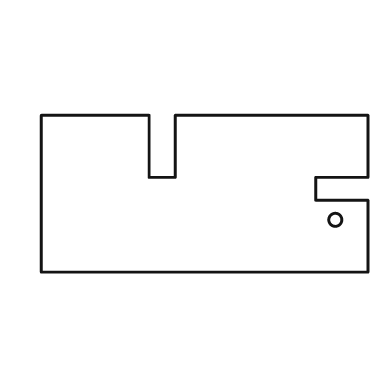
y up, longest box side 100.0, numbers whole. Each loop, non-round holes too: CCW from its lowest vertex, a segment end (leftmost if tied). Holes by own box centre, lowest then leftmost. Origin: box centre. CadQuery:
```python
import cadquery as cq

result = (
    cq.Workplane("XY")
    .moveTo(-50.0, -24.0)
    .lineTo(50.0, -24.0)
    .lineTo(50.0, -2.0)
    .lineTo(34.0, -2.0)
    .lineTo(34.0, 5.0)
    .lineTo(50.0, 5.0)
    .lineTo(50.0, 24.0)
    .lineTo(-9.0, 24.0)
    .lineTo(-9.0, 5.0)
    .lineTo(-17.0, 5.0)
    .lineTo(-17.0, 24.0)
    .lineTo(-50.0, 24.0)
    .close()
    .moveTo(40.0, -8.0)
    .circle(2.0)
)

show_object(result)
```